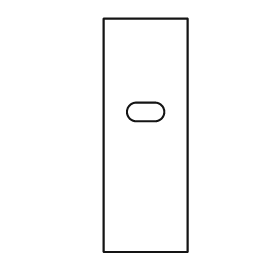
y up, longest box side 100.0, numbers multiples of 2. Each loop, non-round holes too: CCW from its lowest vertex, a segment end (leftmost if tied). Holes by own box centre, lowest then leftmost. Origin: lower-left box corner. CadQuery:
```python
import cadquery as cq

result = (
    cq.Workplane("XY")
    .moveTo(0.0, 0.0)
    .lineTo(36.0, 0.0)
    .lineTo(36.0, 100.0)
    .lineTo(0.0, 100.0)
    .close()
    .moveTo(14.0, 56.0)
    .lineTo(22.0, 56.0)
    .threePointArc((26.0, 60.0), (22.0, 64.0))
    .lineTo(14.0, 64.0)
    .threePointArc((10.0, 60.0), (14.0, 56.0))
    .close()
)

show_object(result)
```